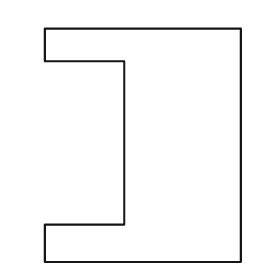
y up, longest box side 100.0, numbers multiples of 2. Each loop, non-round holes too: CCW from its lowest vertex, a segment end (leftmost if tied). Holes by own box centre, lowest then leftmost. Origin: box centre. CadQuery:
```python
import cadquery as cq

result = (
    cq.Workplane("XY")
    .moveTo(-42.0, -50.0)
    .lineTo(42.0, -50.0)
    .lineTo(42.0, 50.0)
    .lineTo(-42.0, 50.0)
    .lineTo(-42.0, 36.0)
    .lineTo(-8.0, 36.0)
    .lineTo(-8.0, -34.0)
    .lineTo(-42.0, -34.0)
    .close()
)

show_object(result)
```